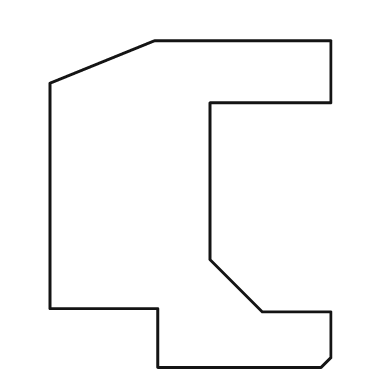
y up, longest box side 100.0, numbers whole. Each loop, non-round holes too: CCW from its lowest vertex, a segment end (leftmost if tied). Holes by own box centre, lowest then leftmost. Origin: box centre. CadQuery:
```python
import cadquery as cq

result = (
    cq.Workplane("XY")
    .moveTo(-10.0, -50.0)
    .lineTo(40.0, -50.0)
    .lineTo(43.0, -47.0)
    .lineTo(43.0, -33.0)
    .lineTo(22.0, -33.0)
    .lineTo(6.0, -17.0)
    .lineTo(6.0, 31.0)
    .lineTo(43.0, 31.0)
    .lineTo(43.0, 50.0)
    .lineTo(-11.0, 50.0)
    .lineTo(-43.0, 37.0)
    .lineTo(-43.0, -32.0)
    .lineTo(-10.0, -32.0)
    .close()
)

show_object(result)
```